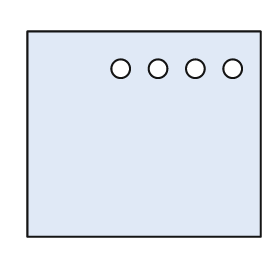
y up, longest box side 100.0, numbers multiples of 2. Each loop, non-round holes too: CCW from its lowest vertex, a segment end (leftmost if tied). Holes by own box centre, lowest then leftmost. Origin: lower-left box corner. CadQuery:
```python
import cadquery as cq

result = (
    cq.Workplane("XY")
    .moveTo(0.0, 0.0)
    .lineTo(100.0, 0.0)
    .lineTo(100.0, 88.0)
    .lineTo(0.0, 88.0)
    .close()
    .moveTo(40.0, 72.0)
    .circle(4.0)
    .moveTo(56.0, 72.0)
    .circle(4.0)
    .moveTo(72.0, 72.0)
    .circle(4.0)
    .moveTo(88.0, 72.0)
    .circle(4.0)
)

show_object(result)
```